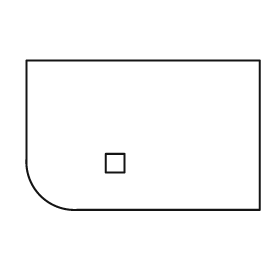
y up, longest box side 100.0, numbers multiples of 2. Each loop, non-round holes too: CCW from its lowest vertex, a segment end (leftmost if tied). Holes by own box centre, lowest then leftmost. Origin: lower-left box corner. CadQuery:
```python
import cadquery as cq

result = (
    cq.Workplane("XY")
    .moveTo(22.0, 0.0)
    .lineTo(100.0, 0.0)
    .lineTo(100.0, 64.0)
    .lineTo(0.0, 64.0)
    .lineTo(0.0, 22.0)
    .threePointArc((6.0, 6.0), (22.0, 0.0))
    .close()
    .moveTo(34.0, 16.0)
    .lineTo(42.0, 16.0)
    .lineTo(42.0, 24.0)
    .lineTo(34.0, 24.0)
    .close()
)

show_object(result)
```